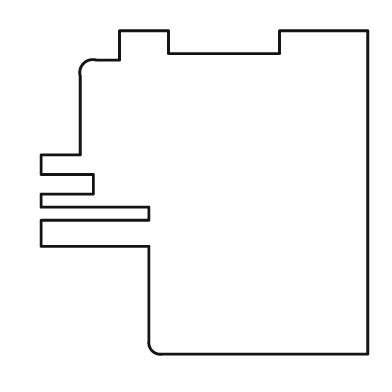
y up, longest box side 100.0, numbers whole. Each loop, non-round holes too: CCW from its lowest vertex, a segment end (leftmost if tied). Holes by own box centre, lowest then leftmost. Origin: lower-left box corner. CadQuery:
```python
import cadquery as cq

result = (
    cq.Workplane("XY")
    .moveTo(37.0, 0.0)
    .lineTo(100.0, 0.0)
    .lineTo(100.0, 99.0)
    .lineTo(73.0, 99.0)
    .lineTo(73.0, 92.0)
    .lineTo(39.0, 92.0)
    .lineTo(39.0, 99.0)
    .lineTo(24.0, 99.0)
    .lineTo(24.0, 90.0)
    .lineTo(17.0, 90.0)
    .threePointArc((13.0, 89.0), (12.0, 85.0))
    .lineTo(12.0, 61.0)
    .lineTo(0.0, 61.0)
    .lineTo(0.0, 55.0)
    .lineTo(16.0, 55.0)
    .lineTo(16.0, 49.0)
    .lineTo(0.0, 49.0)
    .lineTo(0.0, 45.0)
    .lineTo(33.0, 45.0)
    .lineTo(33.0, 41.0)
    .lineTo(0.0, 41.0)
    .lineTo(0.0, 33.0)
    .lineTo(33.0, 33.0)
    .lineTo(33.0, 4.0)
    .threePointArc((34.0, 1.0), (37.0, 0.0))
    .close()
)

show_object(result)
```